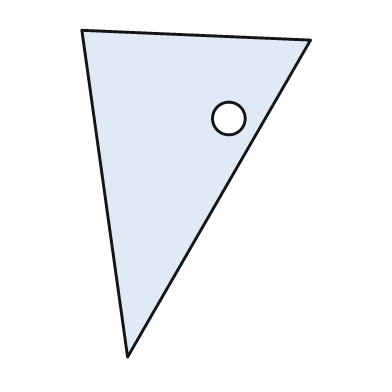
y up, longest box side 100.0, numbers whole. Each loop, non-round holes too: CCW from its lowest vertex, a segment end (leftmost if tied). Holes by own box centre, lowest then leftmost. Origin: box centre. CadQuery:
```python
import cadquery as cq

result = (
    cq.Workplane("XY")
    .moveTo(-21.0, -50.0)
    .lineTo(35.0, 47.0)
    .lineTo(-35.0, 50.0)
    .close()
    .moveTo(10.0, 23.0)
    .circle(5.0)
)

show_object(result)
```